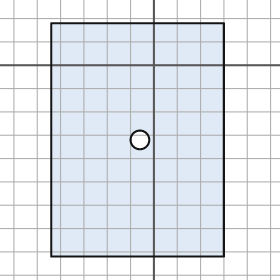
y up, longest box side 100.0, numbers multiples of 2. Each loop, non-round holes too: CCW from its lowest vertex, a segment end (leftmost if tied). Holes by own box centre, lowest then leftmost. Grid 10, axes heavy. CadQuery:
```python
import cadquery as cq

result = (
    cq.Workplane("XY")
    .moveTo(-44.0, -82.0)
    .lineTo(30.0, -82.0)
    .lineTo(30.0, 18.0)
    .lineTo(-44.0, 18.0)
    .close()
    .moveTo(-6.0, -32.0)
    .circle(4.0)
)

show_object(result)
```